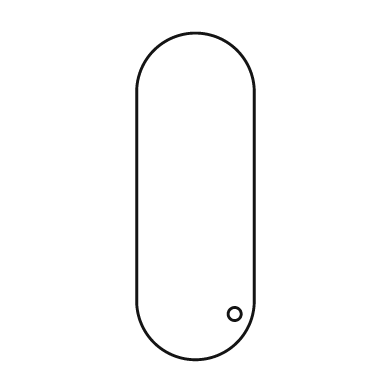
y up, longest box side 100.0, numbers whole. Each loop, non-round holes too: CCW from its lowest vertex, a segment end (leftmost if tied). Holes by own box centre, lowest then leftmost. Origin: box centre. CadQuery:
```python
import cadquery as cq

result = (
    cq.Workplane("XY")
    .moveTo(-18.0, -32.0)
    .threePointArc((0.0, -50.0), (18.0, -32.0))
    .lineTo(18.0, 32.0)
    .threePointArc((0.0, 50.0), (-18.0, 32.0))
    .close()
    .moveTo(12.0, -36.0)
    .circle(2.0)
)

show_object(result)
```